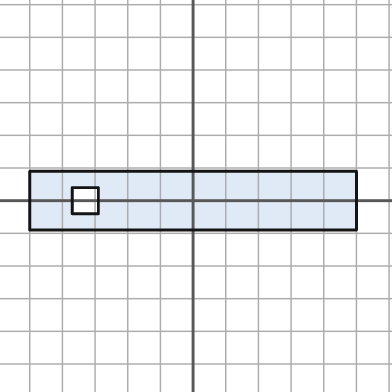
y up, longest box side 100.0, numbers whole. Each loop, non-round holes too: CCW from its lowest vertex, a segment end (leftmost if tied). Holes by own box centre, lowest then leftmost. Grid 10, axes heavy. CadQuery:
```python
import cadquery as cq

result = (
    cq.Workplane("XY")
    .moveTo(-50.0, -9.0)
    .lineTo(50.0, -9.0)
    .lineTo(50.0, 9.0)
    .lineTo(-50.0, 9.0)
    .close()
    .moveTo(-37.0, -4.0)
    .lineTo(-29.0, -4.0)
    .lineTo(-29.0, 4.0)
    .lineTo(-37.0, 4.0)
    .close()
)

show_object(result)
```